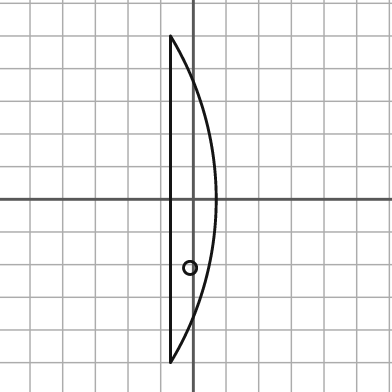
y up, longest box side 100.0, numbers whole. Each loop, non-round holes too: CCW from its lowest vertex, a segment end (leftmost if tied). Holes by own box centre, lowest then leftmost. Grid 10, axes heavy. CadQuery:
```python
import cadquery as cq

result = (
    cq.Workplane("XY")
    .moveTo(-7.0, -50.0)
    .threePointArc((7.0, 0.0), (-7.0, 50.0))
    .close()
    .moveTo(-1.0, -21.0)
    .circle(2.0)
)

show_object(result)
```